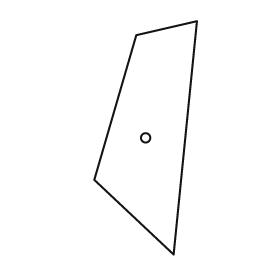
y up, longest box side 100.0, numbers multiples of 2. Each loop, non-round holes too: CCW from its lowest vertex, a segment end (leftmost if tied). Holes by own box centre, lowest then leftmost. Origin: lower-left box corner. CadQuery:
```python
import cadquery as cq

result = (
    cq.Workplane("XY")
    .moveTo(34.0, 0.0)
    .lineTo(44.0, 100.0)
    .lineTo(18.0, 94.0)
    .lineTo(0.0, 32.0)
    .close()
    .moveTo(22.0, 50.0)
    .circle(2.0)
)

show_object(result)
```